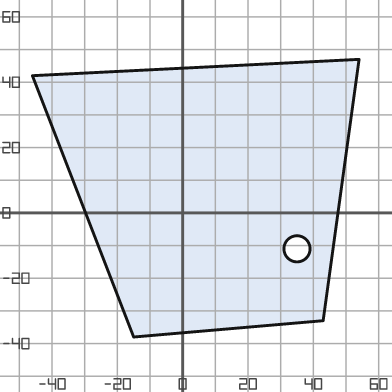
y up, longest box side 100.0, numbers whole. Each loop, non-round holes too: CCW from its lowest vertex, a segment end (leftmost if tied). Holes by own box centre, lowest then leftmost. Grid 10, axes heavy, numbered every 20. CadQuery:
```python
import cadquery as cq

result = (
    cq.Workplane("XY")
    .moveTo(-15.0, -38.0)
    .lineTo(43.0, -33.0)
    .lineTo(54.0, 47.0)
    .lineTo(-46.0, 42.0)
    .close()
    .moveTo(35.0, -11.0)
    .circle(4.0)
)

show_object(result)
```